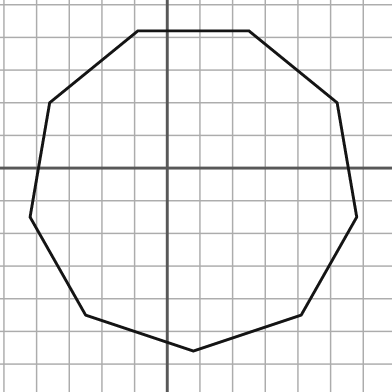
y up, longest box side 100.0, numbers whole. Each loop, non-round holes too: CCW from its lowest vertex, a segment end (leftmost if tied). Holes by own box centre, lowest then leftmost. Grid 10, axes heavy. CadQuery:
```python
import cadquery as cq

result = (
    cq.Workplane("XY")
    .moveTo(8.0, -56.0)
    .lineTo(41.0, -45.0)
    .lineTo(58.0, -15.0)
    .lineTo(52.0, 20.0)
    .lineTo(25.0, 42.0)
    .lineTo(-9.0, 42.0)
    .lineTo(-36.0, 20.0)
    .lineTo(-42.0, -15.0)
    .lineTo(-25.0, -45.0)
    .close()
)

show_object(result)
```